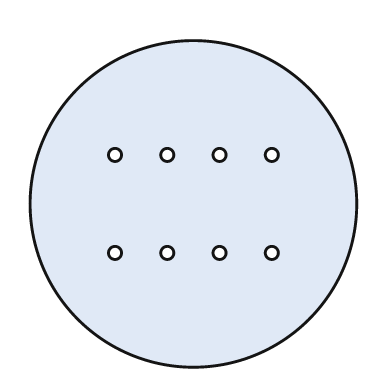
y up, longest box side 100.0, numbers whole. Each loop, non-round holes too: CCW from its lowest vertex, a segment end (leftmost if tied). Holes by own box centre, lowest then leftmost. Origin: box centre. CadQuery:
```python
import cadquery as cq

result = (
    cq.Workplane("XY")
    .moveTo(0.0, 0.0)
    .circle(50.0)
    .moveTo(-24.0, -15.0)
    .circle(2.0)
    .moveTo(-8.0, -15.0)
    .circle(2.0)
    .moveTo(8.0, -15.0)
    .circle(2.0)
    .moveTo(24.0, -15.0)
    .circle(2.0)
    .moveTo(-24.0, 15.0)
    .circle(2.0)
    .moveTo(-8.0, 15.0)
    .circle(2.0)
    .moveTo(8.0, 15.0)
    .circle(2.0)
    .moveTo(24.0, 15.0)
    .circle(2.0)
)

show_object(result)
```